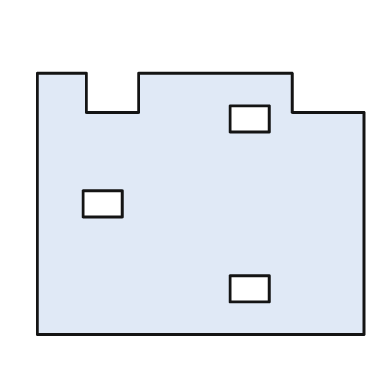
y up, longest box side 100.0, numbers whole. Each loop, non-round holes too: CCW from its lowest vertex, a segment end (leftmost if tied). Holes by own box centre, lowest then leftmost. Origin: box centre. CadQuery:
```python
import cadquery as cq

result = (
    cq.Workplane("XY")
    .moveTo(-50.0, -40.0)
    .lineTo(50.0, -40.0)
    .lineTo(50.0, 28.0)
    .lineTo(28.0, 28.0)
    .lineTo(28.0, 40.0)
    .lineTo(-19.0, 40.0)
    .lineTo(-19.0, 28.0)
    .lineTo(-35.0, 28.0)
    .lineTo(-35.0, 40.0)
    .lineTo(-50.0, 40.0)
    .close()
    .moveTo(9.0, -30.0)
    .lineTo(21.0, -30.0)
    .lineTo(21.0, -22.0)
    .lineTo(9.0, -22.0)
    .close()
    .moveTo(-36.0, -4.0)
    .lineTo(-24.0, -4.0)
    .lineTo(-24.0, 4.0)
    .lineTo(-36.0, 4.0)
    .close()
    .moveTo(9.0, 22.0)
    .lineTo(21.0, 22.0)
    .lineTo(21.0, 30.0)
    .lineTo(9.0, 30.0)
    .close()
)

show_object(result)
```